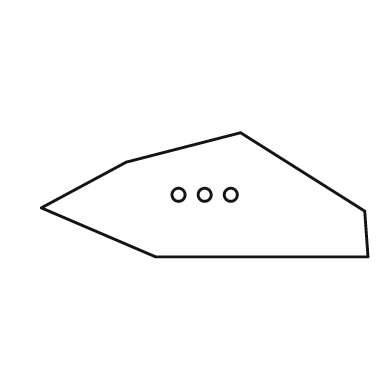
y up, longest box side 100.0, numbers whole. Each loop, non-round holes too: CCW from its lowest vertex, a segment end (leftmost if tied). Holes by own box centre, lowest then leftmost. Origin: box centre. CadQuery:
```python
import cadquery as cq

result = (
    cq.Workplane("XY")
    .moveTo(-15.0, -19.0)
    .lineTo(50.0, -19.0)
    .lineTo(49.0, -5.0)
    .lineTo(11.0, 19.0)
    .lineTo(-24.0, 10.0)
    .lineTo(-50.0, -4.0)
    .close()
    .moveTo(-8.0, 0.0)
    .circle(2.0)
    .moveTo(0.0, 0.0)
    .circle(2.0)
    .moveTo(8.0, 0.0)
    .circle(2.0)
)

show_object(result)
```